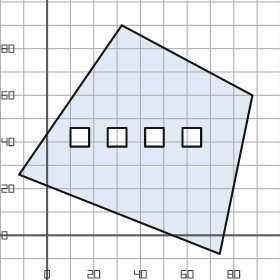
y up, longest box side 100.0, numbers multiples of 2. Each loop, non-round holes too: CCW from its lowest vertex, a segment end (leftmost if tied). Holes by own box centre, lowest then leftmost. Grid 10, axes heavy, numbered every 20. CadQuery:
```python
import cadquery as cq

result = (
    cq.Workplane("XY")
    .moveTo(74.0, -8.0)
    .lineTo(88.0, 60.0)
    .lineTo(32.0, 90.0)
    .lineTo(-12.0, 26.0)
    .close()
    .moveTo(10.0, 38.0)
    .lineTo(18.0, 38.0)
    .lineTo(18.0, 46.0)
    .lineTo(10.0, 46.0)
    .close()
    .moveTo(26.0, 38.0)
    .lineTo(34.0, 38.0)
    .lineTo(34.0, 46.0)
    .lineTo(26.0, 46.0)
    .close()
    .moveTo(42.0, 38.0)
    .lineTo(50.0, 38.0)
    .lineTo(50.0, 46.0)
    .lineTo(42.0, 46.0)
    .close()
    .moveTo(58.0, 38.0)
    .lineTo(66.0, 38.0)
    .lineTo(66.0, 46.0)
    .lineTo(58.0, 46.0)
    .close()
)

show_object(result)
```